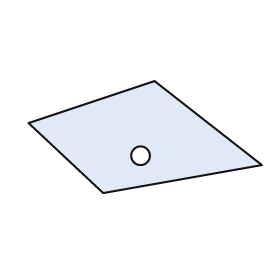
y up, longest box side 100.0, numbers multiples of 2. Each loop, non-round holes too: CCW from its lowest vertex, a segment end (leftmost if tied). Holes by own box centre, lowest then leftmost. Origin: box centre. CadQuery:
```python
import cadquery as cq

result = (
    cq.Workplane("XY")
    .moveTo(-18.0, -24.0)
    .lineTo(50.0, -12.0)
    .lineTo(4.0, 24.0)
    .lineTo(-50.0, 6.0)
    .close()
    .moveTo(-2.0, -8.0)
    .circle(4.0)
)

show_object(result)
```